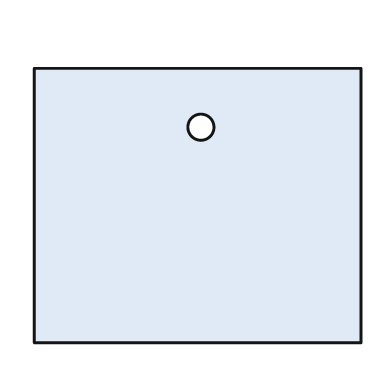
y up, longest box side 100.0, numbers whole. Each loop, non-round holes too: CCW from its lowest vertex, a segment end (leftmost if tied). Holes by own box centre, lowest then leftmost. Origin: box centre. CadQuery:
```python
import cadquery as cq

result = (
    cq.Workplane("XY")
    .moveTo(-50.0, -42.0)
    .lineTo(50.0, -42.0)
    .lineTo(50.0, 42.0)
    .lineTo(-50.0, 42.0)
    .close()
    .moveTo(1.0, 24.0)
    .circle(4.0)
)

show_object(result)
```